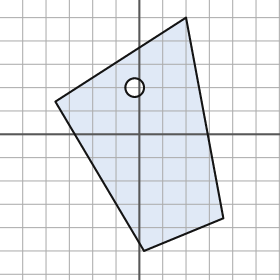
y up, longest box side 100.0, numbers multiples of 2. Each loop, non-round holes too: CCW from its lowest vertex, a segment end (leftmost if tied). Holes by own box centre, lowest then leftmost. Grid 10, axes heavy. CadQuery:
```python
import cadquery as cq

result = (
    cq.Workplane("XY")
    .moveTo(2.0, -50.0)
    .lineTo(36.0, -36.0)
    .lineTo(20.0, 50.0)
    .lineTo(-36.0, 14.0)
    .close()
    .moveTo(-2.0, 20.0)
    .circle(4.0)
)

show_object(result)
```